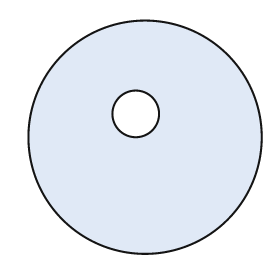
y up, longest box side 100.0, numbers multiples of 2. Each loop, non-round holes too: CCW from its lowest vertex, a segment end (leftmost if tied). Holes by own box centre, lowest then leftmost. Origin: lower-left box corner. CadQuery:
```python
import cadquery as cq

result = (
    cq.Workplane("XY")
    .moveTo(50.0, 50.0)
    .circle(50.0)
    .moveTo(46.0, 60.0)
    .circle(10.0)
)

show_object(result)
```